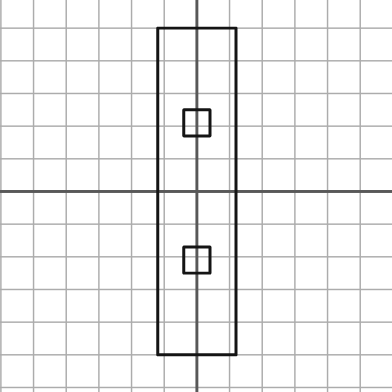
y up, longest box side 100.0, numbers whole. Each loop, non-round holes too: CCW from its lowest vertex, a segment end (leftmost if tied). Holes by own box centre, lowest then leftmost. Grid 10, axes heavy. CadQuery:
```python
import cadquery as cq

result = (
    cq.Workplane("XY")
    .moveTo(-12.0, -50.0)
    .lineTo(12.0, -50.0)
    .lineTo(12.0, 50.0)
    .lineTo(-12.0, 50.0)
    .close()
    .moveTo(-4.0, -25.0)
    .lineTo(4.0, -25.0)
    .lineTo(4.0, -17.0)
    .lineTo(-4.0, -17.0)
    .close()
    .moveTo(-4.0, 17.0)
    .lineTo(4.0, 17.0)
    .lineTo(4.0, 25.0)
    .lineTo(-4.0, 25.0)
    .close()
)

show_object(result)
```